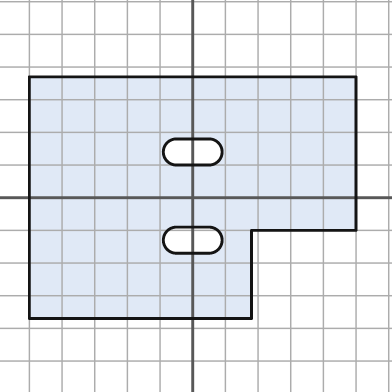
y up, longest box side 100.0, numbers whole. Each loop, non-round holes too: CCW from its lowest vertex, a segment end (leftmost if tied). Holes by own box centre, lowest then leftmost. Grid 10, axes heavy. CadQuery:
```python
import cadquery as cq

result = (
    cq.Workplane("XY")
    .moveTo(-50.0, -37.0)
    .lineTo(18.0, -37.0)
    .lineTo(18.0, -10.0)
    .lineTo(50.0, -10.0)
    .lineTo(50.0, 37.0)
    .lineTo(-50.0, 37.0)
    .close()
    .moveTo(-5.0, -17.0)
    .lineTo(5.0, -17.0)
    .threePointArc((9.0, -13.0), (5.0, -9.0))
    .lineTo(-5.0, -9.0)
    .threePointArc((-9.0, -13.0), (-5.0, -17.0))
    .close()
    .moveTo(-5.0, 10.0)
    .lineTo(5.0, 10.0)
    .threePointArc((9.0, 14.0), (5.0, 18.0))
    .lineTo(-5.0, 18.0)
    .threePointArc((-9.0, 14.0), (-5.0, 10.0))
    .close()
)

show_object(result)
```